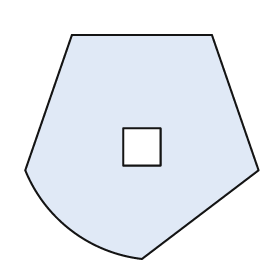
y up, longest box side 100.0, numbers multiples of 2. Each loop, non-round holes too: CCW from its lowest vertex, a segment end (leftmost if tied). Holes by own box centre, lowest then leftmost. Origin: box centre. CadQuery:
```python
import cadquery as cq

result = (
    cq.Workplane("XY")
    .moveTo(0.0, -48.0)
    .lineTo(50.0, -10.0)
    .lineTo(30.0, 48.0)
    .lineTo(-30.0, 48.0)
    .lineTo(-50.0, -10.0)
    .threePointArc((-30.0, -36.0), (0.0, -48.0))
    .close()
    .moveTo(-8.0, -8.0)
    .lineTo(8.0, -8.0)
    .lineTo(8.0, 8.0)
    .lineTo(-8.0, 8.0)
    .close()
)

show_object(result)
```